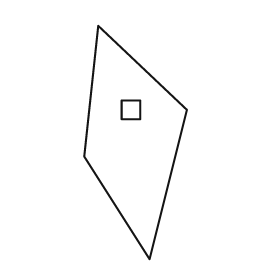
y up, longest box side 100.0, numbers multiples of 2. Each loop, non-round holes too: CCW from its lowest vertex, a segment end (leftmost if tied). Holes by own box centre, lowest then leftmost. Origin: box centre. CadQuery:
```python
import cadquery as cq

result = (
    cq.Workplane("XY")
    .moveTo(6.0, -50.0)
    .lineTo(22.0, 14.0)
    .lineTo(-16.0, 50.0)
    .lineTo(-22.0, -6.0)
    .close()
    .moveTo(-6.0, 10.0)
    .lineTo(2.0, 10.0)
    .lineTo(2.0, 18.0)
    .lineTo(-6.0, 18.0)
    .close()
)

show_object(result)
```